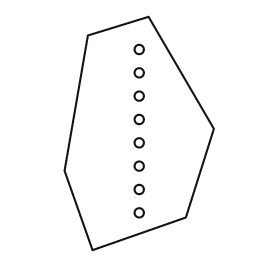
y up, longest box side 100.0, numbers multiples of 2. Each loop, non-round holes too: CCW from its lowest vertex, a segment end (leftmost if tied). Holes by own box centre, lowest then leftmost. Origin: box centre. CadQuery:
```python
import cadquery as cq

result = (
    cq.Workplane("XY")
    .moveTo(-20.0, -50.0)
    .lineTo(20.0, -36.0)
    .lineTo(32.0, 2.0)
    .lineTo(4.0, 50.0)
    .lineTo(-22.0, 42.0)
    .lineTo(-32.0, -16.0)
    .close()
    .moveTo(0.0, -34.0)
    .circle(2.0)
    .moveTo(0.0, -24.0)
    .circle(2.0)
    .moveTo(0.0, -14.0)
    .circle(2.0)
    .moveTo(0.0, -4.0)
    .circle(2.0)
    .moveTo(0.0, 6.0)
    .circle(2.0)
    .moveTo(0.0, 16.0)
    .circle(2.0)
    .moveTo(0.0, 26.0)
    .circle(2.0)
    .moveTo(0.0, 36.0)
    .circle(2.0)
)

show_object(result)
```